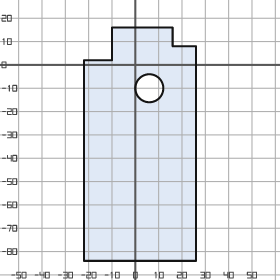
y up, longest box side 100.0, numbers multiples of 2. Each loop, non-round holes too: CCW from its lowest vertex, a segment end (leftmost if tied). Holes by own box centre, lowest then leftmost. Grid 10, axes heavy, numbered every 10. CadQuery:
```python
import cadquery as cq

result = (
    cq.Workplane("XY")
    .moveTo(-22.0, -84.0)
    .lineTo(26.0, -84.0)
    .lineTo(26.0, 8.0)
    .lineTo(16.0, 8.0)
    .lineTo(16.0, 16.0)
    .lineTo(-10.0, 16.0)
    .lineTo(-10.0, 2.0)
    .lineTo(-22.0, 2.0)
    .close()
    .moveTo(6.0, -10.0)
    .circle(6.0)
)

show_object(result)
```